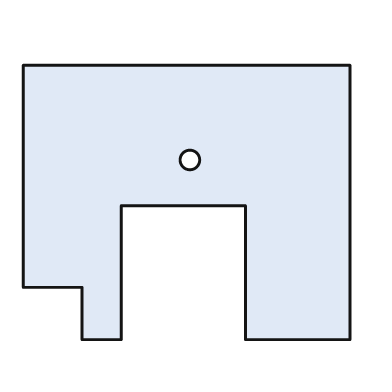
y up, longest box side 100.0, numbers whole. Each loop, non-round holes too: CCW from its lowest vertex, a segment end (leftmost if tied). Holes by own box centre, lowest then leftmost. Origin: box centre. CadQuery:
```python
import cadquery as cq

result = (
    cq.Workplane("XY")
    .moveTo(-32.0, -42.0)
    .lineTo(-20.0, -42.0)
    .lineTo(-20.0, -1.0)
    .lineTo(18.0, -1.0)
    .lineTo(18.0, -42.0)
    .lineTo(50.0, -42.0)
    .lineTo(50.0, 42.0)
    .lineTo(-50.0, 42.0)
    .lineTo(-50.0, -26.0)
    .lineTo(-32.0, -26.0)
    .close()
    .moveTo(1.0, 13.0)
    .circle(3.0)
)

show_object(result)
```